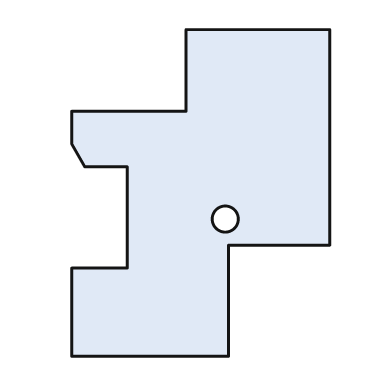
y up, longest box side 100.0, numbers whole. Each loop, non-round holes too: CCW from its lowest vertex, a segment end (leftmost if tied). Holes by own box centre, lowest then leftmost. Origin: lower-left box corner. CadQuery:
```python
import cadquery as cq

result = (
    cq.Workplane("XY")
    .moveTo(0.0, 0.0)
    .lineTo(48.0, 0.0)
    .lineTo(48.0, 34.0)
    .lineTo(79.0, 34.0)
    .lineTo(79.0, 100.0)
    .lineTo(35.0, 100.0)
    .lineTo(35.0, 75.0)
    .lineTo(0.0, 75.0)
    .lineTo(0.0, 65.0)
    .lineTo(4.0, 58.0)
    .lineTo(17.0, 58.0)
    .lineTo(17.0, 27.0)
    .lineTo(0.0, 27.0)
    .close()
    .moveTo(47.0, 42.0)
    .circle(4.0)
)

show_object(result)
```